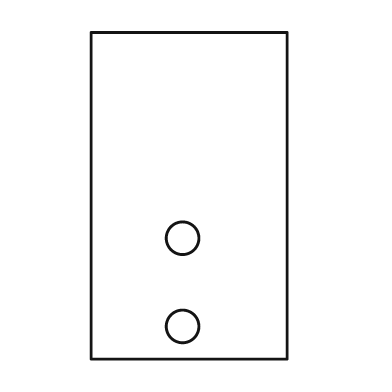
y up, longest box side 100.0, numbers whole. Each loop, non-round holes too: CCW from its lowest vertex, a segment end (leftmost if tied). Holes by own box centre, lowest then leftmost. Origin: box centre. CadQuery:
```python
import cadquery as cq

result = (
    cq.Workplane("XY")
    .moveTo(-30.0, -50.0)
    .lineTo(30.0, -50.0)
    .lineTo(30.0, 50.0)
    .lineTo(-30.0, 50.0)
    .close()
    .moveTo(-2.0, -40.0)
    .circle(5.0)
    .moveTo(-2.0, -13.0)
    .circle(5.0)
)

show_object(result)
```